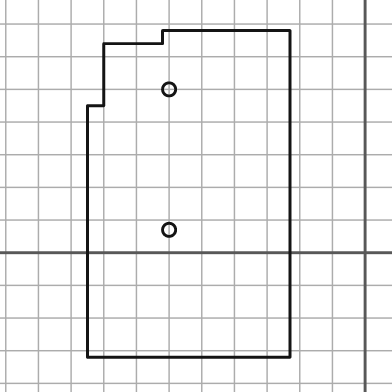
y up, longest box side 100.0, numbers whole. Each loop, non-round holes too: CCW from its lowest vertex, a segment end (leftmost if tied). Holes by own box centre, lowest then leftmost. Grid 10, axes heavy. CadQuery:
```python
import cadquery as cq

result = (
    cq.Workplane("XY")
    .moveTo(-85.0, -32.0)
    .lineTo(-23.0, -32.0)
    .lineTo(-23.0, 68.0)
    .lineTo(-62.0, 68.0)
    .lineTo(-62.0, 64.0)
    .lineTo(-80.0, 64.0)
    .lineTo(-80.0, 45.0)
    .lineTo(-85.0, 45.0)
    .close()
    .moveTo(-60.0, 7.0)
    .circle(2.0)
    .moveTo(-60.0, 50.0)
    .circle(2.0)
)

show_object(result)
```